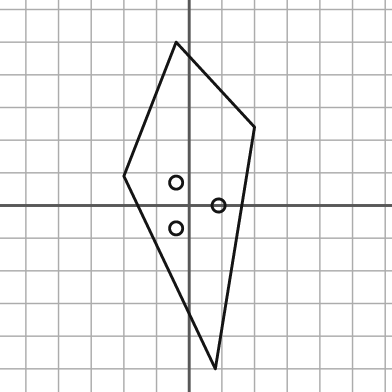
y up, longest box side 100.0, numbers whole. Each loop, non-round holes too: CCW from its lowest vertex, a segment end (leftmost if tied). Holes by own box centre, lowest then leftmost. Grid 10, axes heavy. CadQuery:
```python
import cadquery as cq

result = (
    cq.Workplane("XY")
    .moveTo(8.0, -50.0)
    .lineTo(20.0, 24.0)
    .lineTo(-4.0, 50.0)
    .lineTo(-20.0, 9.0)
    .close()
    .moveTo(-4.0, -7.0)
    .circle(2.0)
    .moveTo(9.0, 0.0)
    .circle(2.0)
    .moveTo(-4.0, 7.0)
    .circle(2.0)
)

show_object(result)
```